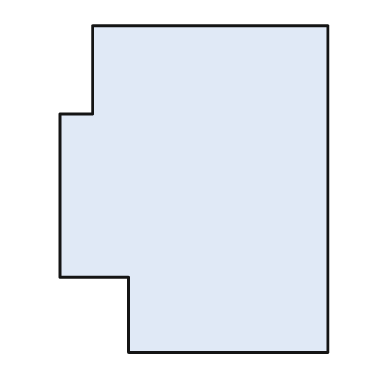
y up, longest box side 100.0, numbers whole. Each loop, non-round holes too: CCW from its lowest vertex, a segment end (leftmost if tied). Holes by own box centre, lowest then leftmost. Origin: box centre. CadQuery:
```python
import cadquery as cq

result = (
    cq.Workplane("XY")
    .moveTo(-20.0, -50.0)
    .lineTo(41.0, -50.0)
    .lineTo(41.0, 50.0)
    .lineTo(-31.0, 50.0)
    .lineTo(-31.0, 23.0)
    .lineTo(-41.0, 23.0)
    .lineTo(-41.0, -27.0)
    .lineTo(-20.0, -27.0)
    .close()
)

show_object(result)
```